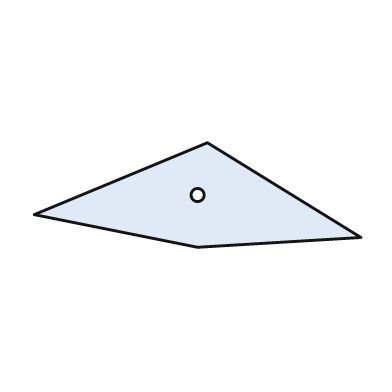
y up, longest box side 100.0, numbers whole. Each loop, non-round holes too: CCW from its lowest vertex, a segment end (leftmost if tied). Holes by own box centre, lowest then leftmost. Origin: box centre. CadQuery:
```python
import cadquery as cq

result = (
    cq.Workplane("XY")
    .moveTo(0.0, -16.0)
    .lineTo(50.0, -13.0)
    .lineTo(3.0, 16.0)
    .lineTo(-50.0, -6.0)
    .close()
    .moveTo(0.0, 0.0)
    .circle(2.0)
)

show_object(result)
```